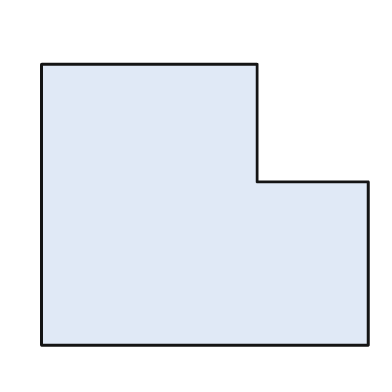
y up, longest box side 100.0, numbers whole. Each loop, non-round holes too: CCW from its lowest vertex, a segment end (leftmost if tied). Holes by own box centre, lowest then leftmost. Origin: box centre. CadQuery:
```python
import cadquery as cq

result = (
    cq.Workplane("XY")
    .moveTo(-50.0, -43.0)
    .lineTo(50.0, -43.0)
    .lineTo(50.0, 7.0)
    .lineTo(16.0, 7.0)
    .lineTo(16.0, 43.0)
    .lineTo(-50.0, 43.0)
    .close()
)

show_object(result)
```